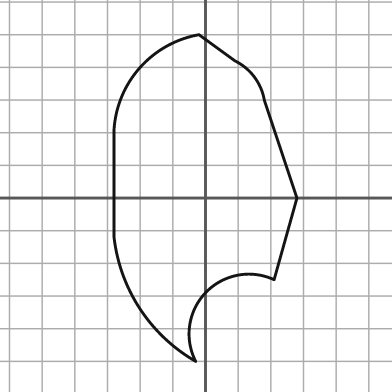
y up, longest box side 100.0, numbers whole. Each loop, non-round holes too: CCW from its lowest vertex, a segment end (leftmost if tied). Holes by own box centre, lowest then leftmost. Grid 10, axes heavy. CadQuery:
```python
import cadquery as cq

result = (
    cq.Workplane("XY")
    .moveTo(-3.0, -50.0)
    .threePointArc((0.0, -29.0), (21.0, -25.0))
    .lineTo(28.0, 0.0)
    .lineTo(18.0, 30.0)
    .threePointArc((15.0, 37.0), (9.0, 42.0))
    .lineTo(-2.0, 50.0)
    .threePointArc((-20.0, 40.0), (-28.0, 21.0))
    .lineTo(-28.0, -12.0)
    .threePointArc((-20.0, -34.0), (-3.0, -50.0))
    .close()
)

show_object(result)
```